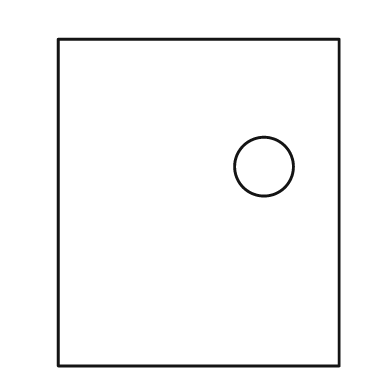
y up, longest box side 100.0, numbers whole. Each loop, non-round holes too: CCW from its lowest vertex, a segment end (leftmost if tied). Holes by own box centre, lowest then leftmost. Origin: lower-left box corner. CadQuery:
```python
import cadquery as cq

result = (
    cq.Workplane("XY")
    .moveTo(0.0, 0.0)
    .lineTo(86.0, 0.0)
    .lineTo(86.0, 100.0)
    .lineTo(0.0, 100.0)
    .close()
    .moveTo(63.0, 61.0)
    .circle(9.0)
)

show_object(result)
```